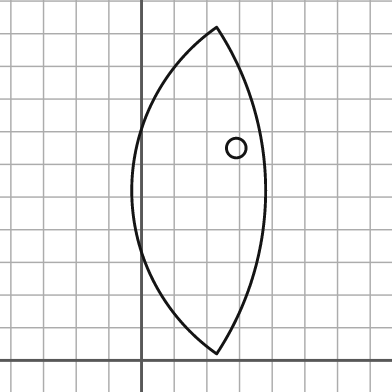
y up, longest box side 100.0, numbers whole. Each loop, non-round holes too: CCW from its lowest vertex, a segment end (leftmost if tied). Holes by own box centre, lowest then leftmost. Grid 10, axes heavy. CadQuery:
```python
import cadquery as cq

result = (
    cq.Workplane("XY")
    .moveTo(23.0, 2.0)
    .threePointArc((38.0, 52.0), (23.0, 102.0))
    .threePointArc((-3.0, 52.0), (23.0, 2.0))
    .close()
    .moveTo(29.0, 65.0)
    .circle(3.0)
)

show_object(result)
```